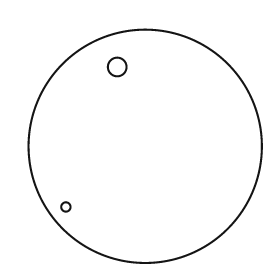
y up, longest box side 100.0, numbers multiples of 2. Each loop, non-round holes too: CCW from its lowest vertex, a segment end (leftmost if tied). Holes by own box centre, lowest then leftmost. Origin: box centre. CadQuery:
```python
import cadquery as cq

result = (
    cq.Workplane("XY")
    .moveTo(0.0, 0.0)
    .circle(50.0)
    .moveTo(-34.0, -26.0)
    .circle(2.0)
    .moveTo(-12.0, 34.0)
    .circle(4.0)
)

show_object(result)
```